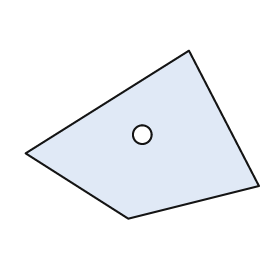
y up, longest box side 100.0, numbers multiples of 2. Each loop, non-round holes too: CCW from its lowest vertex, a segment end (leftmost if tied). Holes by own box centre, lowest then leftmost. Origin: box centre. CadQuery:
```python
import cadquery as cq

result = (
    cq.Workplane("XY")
    .moveTo(-6.0, -36.0)
    .lineTo(50.0, -22.0)
    .lineTo(20.0, 36.0)
    .lineTo(-50.0, -8.0)
    .close()
    .moveTo(0.0, 0.0)
    .circle(4.0)
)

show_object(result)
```